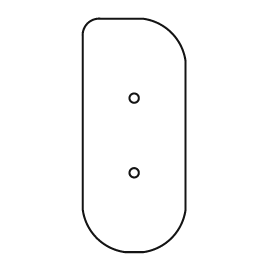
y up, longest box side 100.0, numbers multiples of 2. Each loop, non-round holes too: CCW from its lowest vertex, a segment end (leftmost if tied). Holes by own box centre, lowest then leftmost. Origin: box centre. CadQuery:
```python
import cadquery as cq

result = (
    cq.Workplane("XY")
    .moveTo(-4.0, -50.0)
    .lineTo(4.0, -50.0)
    .threePointArc((16.0, -44.0), (22.0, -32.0))
    .lineTo(22.0, 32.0)
    .threePointArc((16.0, 44.0), (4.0, 50.0))
    .lineTo(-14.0, 50.0)
    .threePointArc((-20.0, 48.0), (-22.0, 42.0))
    .lineTo(-22.0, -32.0)
    .threePointArc((-16.0, -44.0), (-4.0, -50.0))
    .close()
    .moveTo(0.0, -16.0)
    .circle(2.0)
    .moveTo(0.0, 16.0)
    .circle(2.0)
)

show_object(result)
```